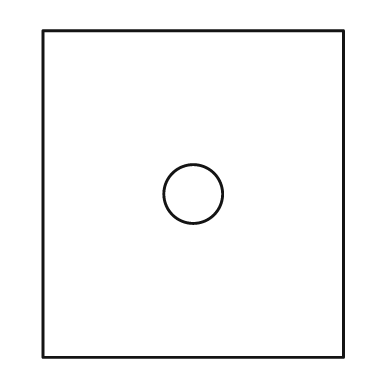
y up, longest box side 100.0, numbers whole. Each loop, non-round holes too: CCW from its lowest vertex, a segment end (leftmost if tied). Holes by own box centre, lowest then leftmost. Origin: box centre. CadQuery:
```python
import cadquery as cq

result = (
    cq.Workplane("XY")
    .moveTo(-46.0, -50.0)
    .lineTo(46.0, -50.0)
    .lineTo(46.0, 50.0)
    .lineTo(-46.0, 50.0)
    .close()
    .moveTo(0.0, 0.0)
    .circle(9.0)
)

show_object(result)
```